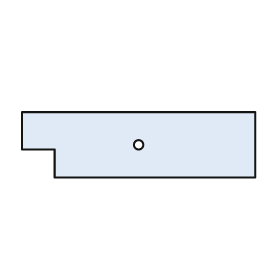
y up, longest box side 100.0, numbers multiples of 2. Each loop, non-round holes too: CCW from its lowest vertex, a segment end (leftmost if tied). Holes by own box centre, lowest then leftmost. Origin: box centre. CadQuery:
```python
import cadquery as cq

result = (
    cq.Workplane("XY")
    .moveTo(-36.0, -14.0)
    .lineTo(50.0, -14.0)
    .lineTo(50.0, 14.0)
    .lineTo(-50.0, 14.0)
    .lineTo(-50.0, -2.0)
    .lineTo(-36.0, -2.0)
    .close()
    .moveTo(0.0, 0.0)
    .circle(2.0)
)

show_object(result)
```